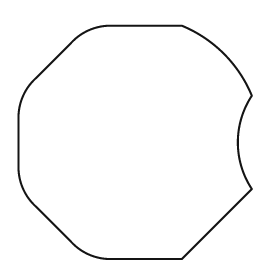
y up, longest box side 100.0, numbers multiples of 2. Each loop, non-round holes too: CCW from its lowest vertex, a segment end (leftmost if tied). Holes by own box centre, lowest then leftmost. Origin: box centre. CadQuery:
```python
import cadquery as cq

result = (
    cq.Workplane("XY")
    .moveTo(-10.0, -50.0)
    .lineTo(20.0, -50.0)
    .lineTo(50.0, -20.0)
    .threePointArc((44.0, 0.0), (50.0, 20.0))
    .threePointArc((38.0, 38.0), (20.0, 50.0))
    .lineTo(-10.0, 50.0)
    .threePointArc((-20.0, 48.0), (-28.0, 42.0))
    .lineTo(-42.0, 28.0)
    .threePointArc((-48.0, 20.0), (-50.0, 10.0))
    .lineTo(-50.0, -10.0)
    .threePointArc((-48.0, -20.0), (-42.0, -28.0))
    .lineTo(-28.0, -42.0)
    .threePointArc((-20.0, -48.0), (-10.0, -50.0))
    .close()
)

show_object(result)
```